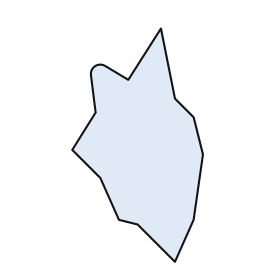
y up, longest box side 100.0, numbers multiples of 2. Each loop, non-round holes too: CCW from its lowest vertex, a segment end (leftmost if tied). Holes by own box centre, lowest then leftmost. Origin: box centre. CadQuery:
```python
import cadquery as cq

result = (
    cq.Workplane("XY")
    .moveTo(16.0, -50.0)
    .lineTo(24.0, -32.0)
    .lineTo(28.0, -4.0)
    .lineTo(24.0, 12.0)
    .lineTo(16.0, 20.0)
    .lineTo(10.0, 50.0)
    .lineTo(-4.0, 28.0)
    .lineTo(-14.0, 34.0)
    .threePointArc((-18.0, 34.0), (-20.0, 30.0))
    .lineTo(-18.0, 14.0)
    .lineTo(-28.0, -2.0)
    .lineTo(-16.0, -14.0)
    .lineTo(-8.0, -32.0)
    .lineTo(0.0, -34.0)
    .close()
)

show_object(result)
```